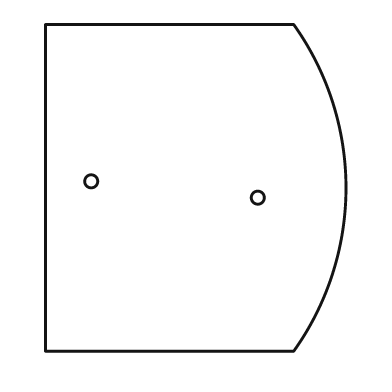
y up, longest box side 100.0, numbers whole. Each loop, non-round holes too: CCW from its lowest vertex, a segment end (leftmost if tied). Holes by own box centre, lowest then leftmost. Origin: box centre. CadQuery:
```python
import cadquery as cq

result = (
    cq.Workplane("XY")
    .moveTo(-46.0, -50.0)
    .lineTo(30.0, -50.0)
    .threePointArc((46.0, 0.0), (30.0, 50.0))
    .lineTo(-46.0, 50.0)
    .close()
    .moveTo(19.0, -3.0)
    .circle(2.0)
    .moveTo(-32.0, 2.0)
    .circle(2.0)
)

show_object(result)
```